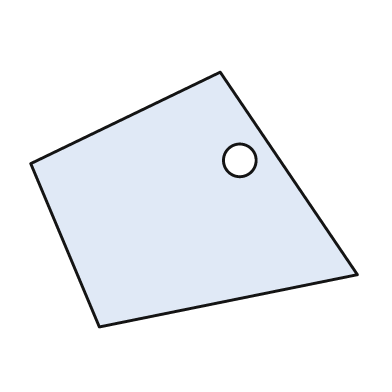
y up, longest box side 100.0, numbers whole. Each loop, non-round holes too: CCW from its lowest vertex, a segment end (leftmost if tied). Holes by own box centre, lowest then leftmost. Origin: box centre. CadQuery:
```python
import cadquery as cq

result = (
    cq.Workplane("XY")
    .moveTo(-29.0, -39.0)
    .lineTo(50.0, -23.0)
    .lineTo(8.0, 39.0)
    .lineTo(-50.0, 11.0)
    .close()
    .moveTo(14.0, 12.0)
    .circle(5.0)
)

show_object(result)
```